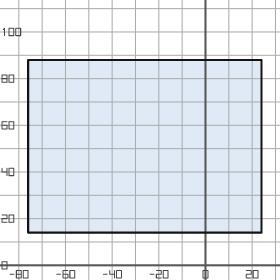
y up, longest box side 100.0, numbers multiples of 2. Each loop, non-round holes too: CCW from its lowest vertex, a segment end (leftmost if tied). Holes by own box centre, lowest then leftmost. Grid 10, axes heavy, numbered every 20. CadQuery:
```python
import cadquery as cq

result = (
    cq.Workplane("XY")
    .moveTo(-76.0, 14.0)
    .lineTo(24.0, 14.0)
    .lineTo(24.0, 88.0)
    .lineTo(-76.0, 88.0)
    .close()
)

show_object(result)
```